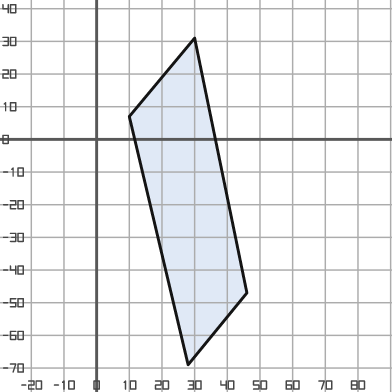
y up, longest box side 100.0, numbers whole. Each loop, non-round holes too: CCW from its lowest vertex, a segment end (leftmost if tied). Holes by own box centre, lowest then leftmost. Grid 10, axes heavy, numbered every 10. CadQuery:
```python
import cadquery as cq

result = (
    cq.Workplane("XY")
    .moveTo(28.0, -69.0)
    .lineTo(46.0, -47.0)
    .lineTo(30.0, 31.0)
    .lineTo(10.0, 7.0)
    .close()
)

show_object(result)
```